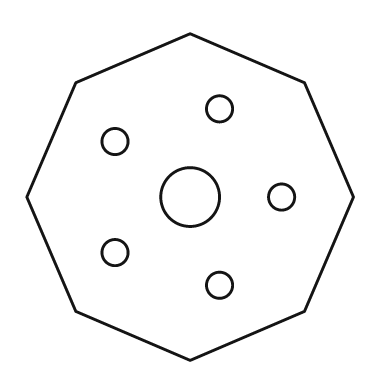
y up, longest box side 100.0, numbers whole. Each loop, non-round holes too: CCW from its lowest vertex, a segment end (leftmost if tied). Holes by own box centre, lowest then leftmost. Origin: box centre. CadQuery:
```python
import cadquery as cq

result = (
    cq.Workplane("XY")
    .moveTo(0.0, -50.0)
    .lineTo(35.0, -35.0)
    .lineTo(50.0, 0.0)
    .lineTo(35.0, 35.0)
    .lineTo(0.0, 50.0)
    .lineTo(-35.0, 35.0)
    .lineTo(-50.0, 0.0)
    .lineTo(-35.0, -35.0)
    .close()
    .moveTo(9.0, -27.0)
    .circle(4.0)
    .moveTo(-23.0, -17.0)
    .circle(4.0)
    .moveTo(0.0, 0.0)
    .circle(9.0)
    .moveTo(28.0, 0.0)
    .circle(4.0)
    .moveTo(-23.0, 17.0)
    .circle(4.0)
    .moveTo(9.0, 27.0)
    .circle(4.0)
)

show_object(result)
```